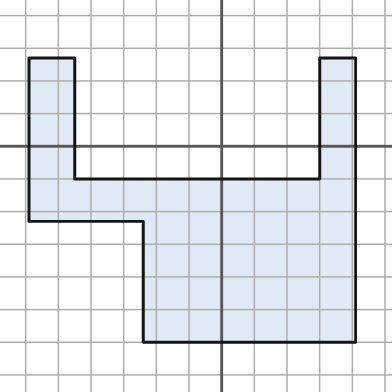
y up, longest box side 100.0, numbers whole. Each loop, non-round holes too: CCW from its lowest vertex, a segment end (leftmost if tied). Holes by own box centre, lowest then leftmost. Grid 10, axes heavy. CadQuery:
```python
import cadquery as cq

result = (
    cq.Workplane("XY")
    .moveTo(-24.0, -60.0)
    .lineTo(41.0, -60.0)
    .lineTo(41.0, 27.0)
    .lineTo(30.0, 27.0)
    .lineTo(30.0, -10.0)
    .lineTo(-45.0, -10.0)
    .lineTo(-45.0, 27.0)
    .lineTo(-59.0, 27.0)
    .lineTo(-59.0, -23.0)
    .lineTo(-24.0, -23.0)
    .close()
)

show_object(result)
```